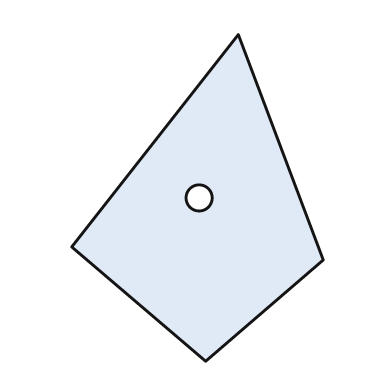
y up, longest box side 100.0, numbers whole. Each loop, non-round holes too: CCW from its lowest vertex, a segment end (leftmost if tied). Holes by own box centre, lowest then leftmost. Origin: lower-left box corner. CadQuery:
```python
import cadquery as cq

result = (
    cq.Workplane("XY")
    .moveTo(41.0, 0.0)
    .lineTo(77.0, 31.0)
    .lineTo(51.0, 100.0)
    .lineTo(0.0, 35.0)
    .close()
    .moveTo(39.0, 50.0)
    .circle(4.0)
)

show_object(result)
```